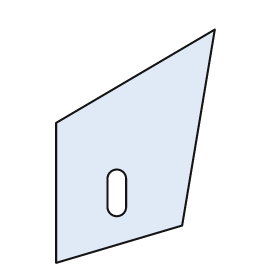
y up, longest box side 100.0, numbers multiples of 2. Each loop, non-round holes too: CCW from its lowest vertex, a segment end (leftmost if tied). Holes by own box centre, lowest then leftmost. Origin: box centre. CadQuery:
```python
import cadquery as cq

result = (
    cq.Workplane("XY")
    .moveTo(-34.0, -50.0)
    .lineTo(20.0, -34.0)
    .lineTo(34.0, 50.0)
    .lineTo(-34.0, 10.0)
    .close()
    .moveTo(-12.0, -26.0)
    .threePointArc((-8.0, -30.0), (-4.0, -26.0))
    .lineTo(-4.0, -14.0)
    .threePointArc((-8.0, -10.0), (-12.0, -14.0))
    .close()
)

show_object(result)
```